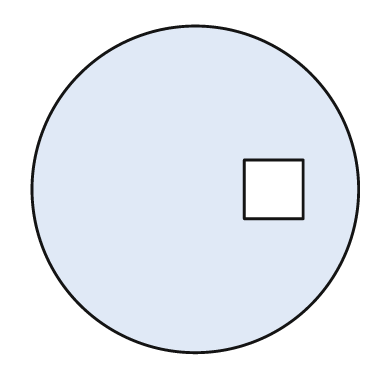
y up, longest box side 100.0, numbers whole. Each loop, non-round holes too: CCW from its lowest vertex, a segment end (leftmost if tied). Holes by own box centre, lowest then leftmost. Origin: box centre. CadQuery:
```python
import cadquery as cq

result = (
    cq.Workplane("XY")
    .moveTo(0.0, 0.0)
    .circle(50.0)
    .moveTo(15.0, -9.0)
    .lineTo(33.0, -9.0)
    .lineTo(33.0, 9.0)
    .lineTo(15.0, 9.0)
    .close()
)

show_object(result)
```